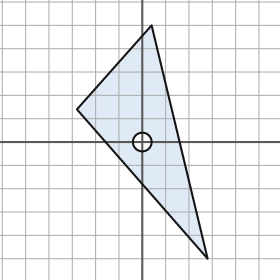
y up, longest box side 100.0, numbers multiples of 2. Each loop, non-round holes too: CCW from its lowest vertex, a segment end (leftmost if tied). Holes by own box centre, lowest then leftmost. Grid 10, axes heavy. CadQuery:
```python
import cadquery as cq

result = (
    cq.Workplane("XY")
    .moveTo(28.0, -50.0)
    .lineTo(4.0, 50.0)
    .lineTo(-28.0, 14.0)
    .close()
    .moveTo(0.0, 0.0)
    .circle(4.0)
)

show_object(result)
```